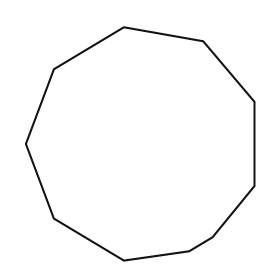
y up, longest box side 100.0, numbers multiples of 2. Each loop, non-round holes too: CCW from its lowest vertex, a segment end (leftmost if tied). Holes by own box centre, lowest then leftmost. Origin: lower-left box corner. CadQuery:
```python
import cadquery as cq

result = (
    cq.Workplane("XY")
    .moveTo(42.0, 0.0)
    .lineTo(70.0, 4.0)
    .lineTo(80.0, 10.0)
    .lineTo(98.0, 32.0)
    .lineTo(98.0, 68.0)
    .lineTo(76.0, 94.0)
    .lineTo(42.0, 100.0)
    .lineTo(12.0, 82.0)
    .lineTo(0.0, 50.0)
    .lineTo(12.0, 18.0)
    .close()
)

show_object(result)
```